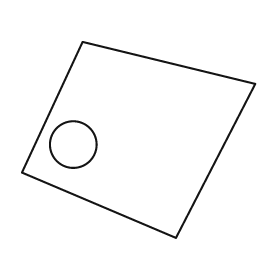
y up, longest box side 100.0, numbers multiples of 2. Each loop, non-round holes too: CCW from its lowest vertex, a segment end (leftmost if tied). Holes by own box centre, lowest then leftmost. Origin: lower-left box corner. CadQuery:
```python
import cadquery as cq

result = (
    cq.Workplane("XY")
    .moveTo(66.0, 0.0)
    .lineTo(100.0, 66.0)
    .lineTo(26.0, 84.0)
    .lineTo(0.0, 28.0)
    .close()
    .moveTo(22.0, 40.0)
    .circle(10.0)
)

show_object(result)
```